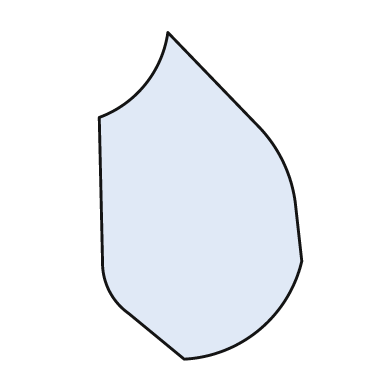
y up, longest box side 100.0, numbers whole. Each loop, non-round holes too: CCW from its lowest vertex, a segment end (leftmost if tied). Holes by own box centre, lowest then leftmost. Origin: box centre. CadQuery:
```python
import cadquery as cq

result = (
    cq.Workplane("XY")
    .moveTo(-5.0, -50.0)
    .threePointArc((18.0, -41.0), (31.0, -20.0))
    .lineTo(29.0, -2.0)
    .threePointArc((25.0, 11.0), (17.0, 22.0))
    .lineTo(-10.0, 50.0)
    .threePointArc((-17.0, 34.0), (-31.0, 24.0))
    .lineTo(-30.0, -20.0)
    .threePointArc((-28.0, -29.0), (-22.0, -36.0))
    .close()
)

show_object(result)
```